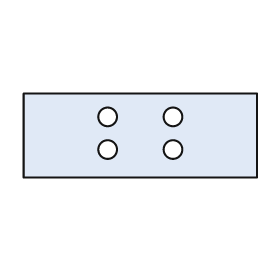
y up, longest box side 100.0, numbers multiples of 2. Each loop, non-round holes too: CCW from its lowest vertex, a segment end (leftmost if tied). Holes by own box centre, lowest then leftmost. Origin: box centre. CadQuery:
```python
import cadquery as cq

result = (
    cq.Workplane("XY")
    .moveTo(-50.0, -18.0)
    .lineTo(50.0, -18.0)
    .lineTo(50.0, 18.0)
    .lineTo(-50.0, 18.0)
    .close()
    .moveTo(-14.0, -6.0)
    .circle(4.0)
    .moveTo(14.0, -6.0)
    .circle(4.0)
    .moveTo(-14.0, 8.0)
    .circle(4.0)
    .moveTo(14.0, 8.0)
    .circle(4.0)
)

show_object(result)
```